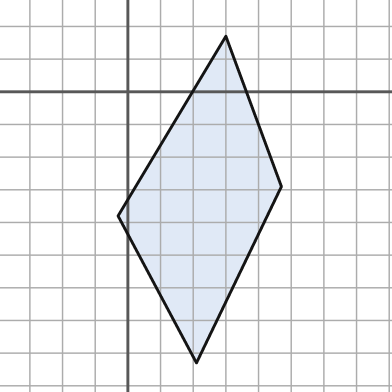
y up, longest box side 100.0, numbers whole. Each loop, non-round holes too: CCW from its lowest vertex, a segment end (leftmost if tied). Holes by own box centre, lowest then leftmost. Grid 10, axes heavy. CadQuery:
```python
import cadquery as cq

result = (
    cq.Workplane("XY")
    .moveTo(21.0, -83.0)
    .lineTo(47.0, -29.0)
    .lineTo(30.0, 17.0)
    .lineTo(-3.0, -38.0)
    .close()
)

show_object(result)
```